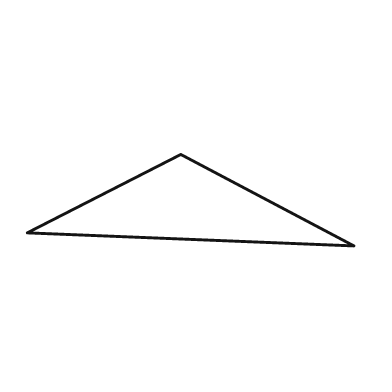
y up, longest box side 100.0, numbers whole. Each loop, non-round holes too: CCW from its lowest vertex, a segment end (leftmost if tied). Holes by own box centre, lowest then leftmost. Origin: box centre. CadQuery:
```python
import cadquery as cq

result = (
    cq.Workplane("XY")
    .moveTo(50.0, -14.0)
    .lineTo(-3.0, 14.0)
    .lineTo(-50.0, -10.0)
    .close()
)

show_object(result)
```